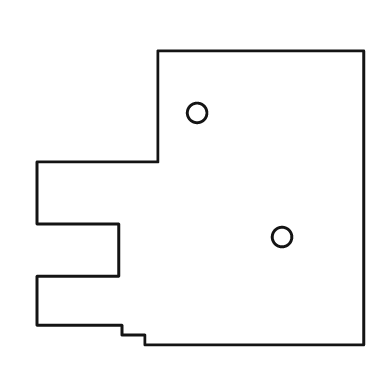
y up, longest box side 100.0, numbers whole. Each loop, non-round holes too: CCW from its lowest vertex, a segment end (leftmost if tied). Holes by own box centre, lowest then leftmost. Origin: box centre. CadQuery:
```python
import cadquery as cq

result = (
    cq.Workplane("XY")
    .moveTo(-17.0, -45.0)
    .lineTo(50.0, -45.0)
    .lineTo(50.0, 45.0)
    .lineTo(-13.0, 45.0)
    .lineTo(-13.0, 11.0)
    .lineTo(-50.0, 11.0)
    .lineTo(-50.0, -8.0)
    .lineTo(-25.0, -8.0)
    .lineTo(-25.0, -24.0)
    .lineTo(-50.0, -24.0)
    .lineTo(-50.0, -39.0)
    .lineTo(-24.0, -39.0)
    .lineTo(-24.0, -42.0)
    .lineTo(-17.0, -42.0)
    .close()
    .moveTo(25.0, -12.0)
    .circle(3.0)
    .moveTo(-1.0, 26.0)
    .circle(3.0)
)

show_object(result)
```